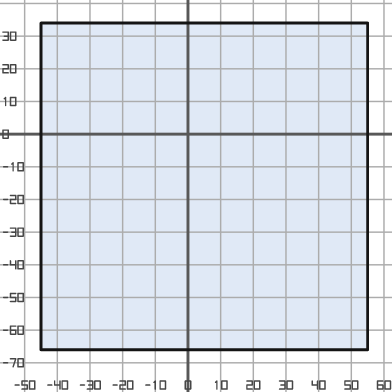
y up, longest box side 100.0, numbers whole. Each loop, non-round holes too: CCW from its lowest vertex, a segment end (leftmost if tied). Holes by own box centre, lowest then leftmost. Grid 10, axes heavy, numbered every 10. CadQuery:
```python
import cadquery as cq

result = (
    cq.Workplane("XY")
    .moveTo(-45.0, -66.0)
    .lineTo(55.0, -66.0)
    .lineTo(55.0, 34.0)
    .lineTo(-45.0, 34.0)
    .close()
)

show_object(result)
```